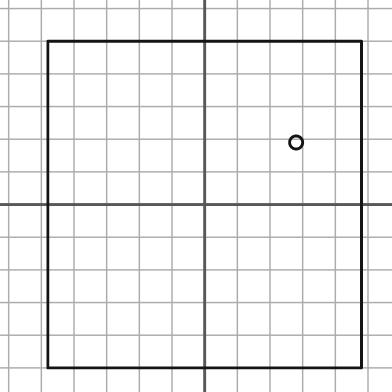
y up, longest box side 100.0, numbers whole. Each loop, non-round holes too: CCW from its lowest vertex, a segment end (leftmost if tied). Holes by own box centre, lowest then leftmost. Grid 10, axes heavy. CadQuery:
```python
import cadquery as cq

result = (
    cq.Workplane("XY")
    .moveTo(-48.0, -50.0)
    .lineTo(48.0, -50.0)
    .lineTo(48.0, 50.0)
    .lineTo(-48.0, 50.0)
    .close()
    .moveTo(28.0, 19.0)
    .circle(2.0)
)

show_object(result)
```